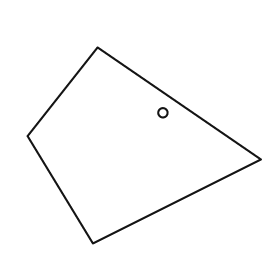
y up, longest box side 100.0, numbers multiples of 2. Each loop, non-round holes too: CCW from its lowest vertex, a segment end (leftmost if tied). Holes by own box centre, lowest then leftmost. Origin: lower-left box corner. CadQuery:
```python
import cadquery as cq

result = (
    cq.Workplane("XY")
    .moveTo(28.0, 0.0)
    .lineTo(100.0, 36.0)
    .lineTo(30.0, 84.0)
    .lineTo(0.0, 46.0)
    .close()
    .moveTo(58.0, 56.0)
    .circle(2.0)
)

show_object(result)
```